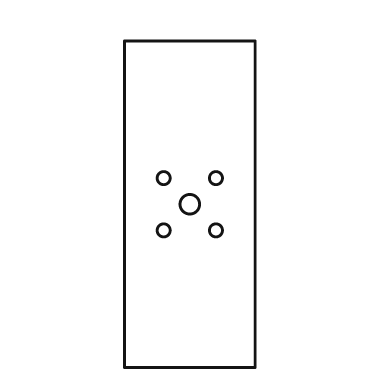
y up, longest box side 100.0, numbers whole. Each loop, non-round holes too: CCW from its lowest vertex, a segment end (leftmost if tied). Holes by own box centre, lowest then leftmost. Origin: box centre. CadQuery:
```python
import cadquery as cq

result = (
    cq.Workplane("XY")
    .moveTo(-20.0, -50.0)
    .lineTo(20.0, -50.0)
    .lineTo(20.0, 50.0)
    .lineTo(-20.0, 50.0)
    .close()
    .moveTo(-8.0, -8.0)
    .circle(2.0)
    .moveTo(8.0, -8.0)
    .circle(2.0)
    .moveTo(0.0, 0.0)
    .circle(3.0)
    .moveTo(-8.0, 8.0)
    .circle(2.0)
    .moveTo(8.0, 8.0)
    .circle(2.0)
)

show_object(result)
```